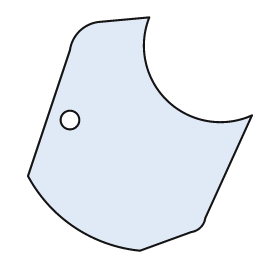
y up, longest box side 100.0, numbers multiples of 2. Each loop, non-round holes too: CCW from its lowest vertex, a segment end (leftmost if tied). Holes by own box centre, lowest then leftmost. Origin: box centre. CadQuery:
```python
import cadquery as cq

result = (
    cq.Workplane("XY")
    .moveTo(0.0, -50.0)
    .lineTo(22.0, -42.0)
    .threePointArc((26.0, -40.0), (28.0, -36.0))
    .lineTo(48.0, 8.0)
    .threePointArc((12.0, 14.0), (4.0, 50.0))
    .lineTo(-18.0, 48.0)
    .threePointArc((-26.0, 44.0), (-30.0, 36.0))
    .lineTo(-48.0, -18.0)
    .threePointArc((-28.0, -40.0), (0.0, -50.0))
    .close()
    .moveTo(-30.0, 6.0)
    .circle(4.0)
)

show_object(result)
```